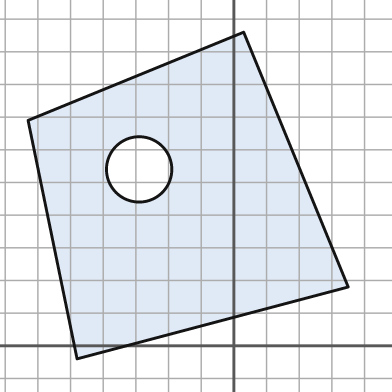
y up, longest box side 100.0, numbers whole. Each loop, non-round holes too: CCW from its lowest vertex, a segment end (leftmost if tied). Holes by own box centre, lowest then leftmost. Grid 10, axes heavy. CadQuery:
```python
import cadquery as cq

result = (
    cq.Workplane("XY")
    .moveTo(-48.0, -4.0)
    .lineTo(35.0, 18.0)
    .lineTo(3.0, 96.0)
    .lineTo(-63.0, 69.0)
    .close()
    .moveTo(-29.0, 54.0)
    .circle(10.0)
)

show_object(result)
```